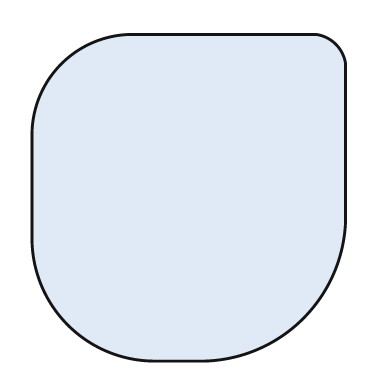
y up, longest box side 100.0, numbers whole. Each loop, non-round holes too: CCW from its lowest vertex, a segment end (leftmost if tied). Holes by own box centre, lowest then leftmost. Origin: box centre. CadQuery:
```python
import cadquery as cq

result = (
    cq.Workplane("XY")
    .moveTo(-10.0, -50.0)
    .lineTo(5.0, -50.0)
    .threePointArc((35.0, -37.0), (48.0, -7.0))
    .lineTo(48.0, 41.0)
    .threePointArc((45.0, 47.0), (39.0, 50.0))
    .lineTo(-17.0, 50.0)
    .threePointArc((-39.0, 41.0), (-48.0, 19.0))
    .lineTo(-48.0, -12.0)
    .threePointArc((-37.0, -39.0), (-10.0, -50.0))
    .close()
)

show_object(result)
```